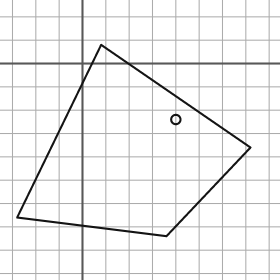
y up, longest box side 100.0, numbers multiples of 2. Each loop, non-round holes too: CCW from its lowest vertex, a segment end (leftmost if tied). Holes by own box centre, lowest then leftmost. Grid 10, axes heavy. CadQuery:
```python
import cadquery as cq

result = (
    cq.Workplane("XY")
    .moveTo(36.0, -74.0)
    .lineTo(72.0, -36.0)
    .lineTo(8.0, 8.0)
    .lineTo(-28.0, -66.0)
    .close()
    .moveTo(40.0, -24.0)
    .circle(2.0)
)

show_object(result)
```